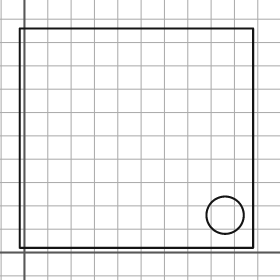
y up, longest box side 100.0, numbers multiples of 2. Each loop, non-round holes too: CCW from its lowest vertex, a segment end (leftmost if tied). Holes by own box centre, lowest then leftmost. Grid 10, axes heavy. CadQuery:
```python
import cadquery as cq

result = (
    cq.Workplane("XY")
    .moveTo(-2.0, 2.0)
    .lineTo(98.0, 2.0)
    .lineTo(98.0, 96.0)
    .lineTo(-2.0, 96.0)
    .close()
    .moveTo(86.0, 16.0)
    .circle(8.0)
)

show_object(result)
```